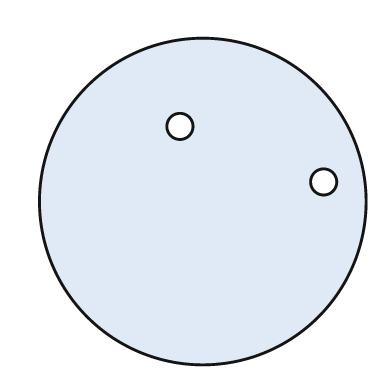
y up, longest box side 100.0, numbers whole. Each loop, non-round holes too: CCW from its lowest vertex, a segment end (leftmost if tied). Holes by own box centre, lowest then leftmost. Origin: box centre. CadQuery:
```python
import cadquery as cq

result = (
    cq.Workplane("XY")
    .moveTo(0.0, 0.0)
    .circle(50.0)
    .moveTo(37.0, 6.0)
    .circle(4.0)
    .moveTo(-7.0, 23.0)
    .circle(4.0)
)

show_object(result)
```